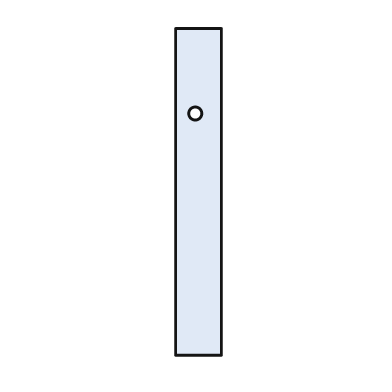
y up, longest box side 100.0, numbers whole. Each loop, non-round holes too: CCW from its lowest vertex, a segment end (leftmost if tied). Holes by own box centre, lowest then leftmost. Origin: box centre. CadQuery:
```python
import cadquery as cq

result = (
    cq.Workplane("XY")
    .moveTo(-7.0, -50.0)
    .lineTo(7.0, -50.0)
    .lineTo(7.0, 50.0)
    .lineTo(-7.0, 50.0)
    .close()
    .moveTo(-1.0, 24.0)
    .circle(2.0)
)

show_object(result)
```